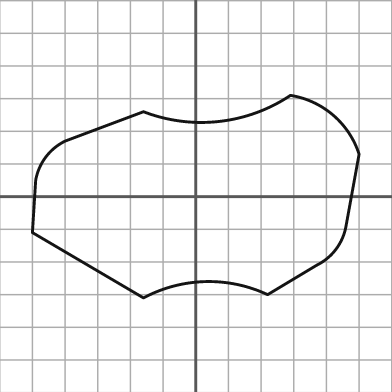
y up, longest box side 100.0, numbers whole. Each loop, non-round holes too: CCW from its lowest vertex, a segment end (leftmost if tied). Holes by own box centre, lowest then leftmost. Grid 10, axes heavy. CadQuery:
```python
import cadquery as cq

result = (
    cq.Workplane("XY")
    .moveTo(-16.0, -31.0)
    .threePointArc((3.0, -26.0), (22.0, -30.0))
    .lineTo(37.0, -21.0)
    .threePointArc((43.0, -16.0), (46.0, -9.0))
    .lineTo(50.0, 13.0)
    .threePointArc((42.0, 25.0), (29.0, 31.0))
    .threePointArc((7.0, 23.0), (-16.0, 26.0))
    .lineTo(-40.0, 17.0)
    .threePointArc((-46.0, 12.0), (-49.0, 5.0))
    .lineTo(-50.0, -11.0)
    .close()
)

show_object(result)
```